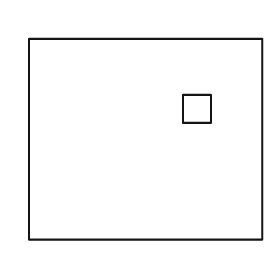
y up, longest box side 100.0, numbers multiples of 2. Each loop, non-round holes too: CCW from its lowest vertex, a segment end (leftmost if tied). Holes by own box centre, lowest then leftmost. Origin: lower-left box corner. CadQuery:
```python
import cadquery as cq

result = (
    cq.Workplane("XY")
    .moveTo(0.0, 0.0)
    .lineTo(100.0, 0.0)
    .lineTo(100.0, 86.0)
    .lineTo(0.0, 86.0)
    .close()
    .moveTo(66.0, 50.0)
    .lineTo(78.0, 50.0)
    .lineTo(78.0, 62.0)
    .lineTo(66.0, 62.0)
    .close()
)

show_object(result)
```